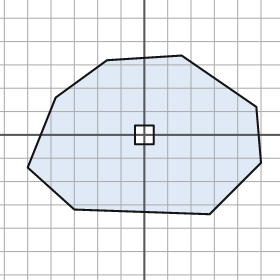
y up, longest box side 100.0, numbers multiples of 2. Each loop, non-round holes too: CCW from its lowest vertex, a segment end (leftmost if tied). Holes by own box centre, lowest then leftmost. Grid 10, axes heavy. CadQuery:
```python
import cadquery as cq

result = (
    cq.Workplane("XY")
    .moveTo(28.0, -34.0)
    .lineTo(50.0, -12.0)
    .lineTo(48.0, 12.0)
    .lineTo(16.0, 34.0)
    .lineTo(-16.0, 32.0)
    .lineTo(-38.0, 16.0)
    .lineTo(-50.0, -14.0)
    .lineTo(-30.0, -32.0)
    .close()
    .moveTo(-4.0, -4.0)
    .lineTo(4.0, -4.0)
    .lineTo(4.0, 4.0)
    .lineTo(-4.0, 4.0)
    .close()
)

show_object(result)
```